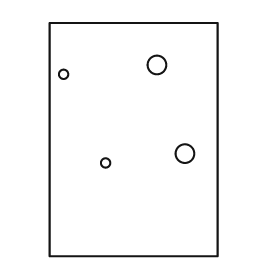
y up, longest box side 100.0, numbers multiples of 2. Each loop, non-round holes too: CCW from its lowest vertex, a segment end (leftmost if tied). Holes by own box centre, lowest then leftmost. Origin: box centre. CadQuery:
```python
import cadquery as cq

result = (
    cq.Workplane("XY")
    .moveTo(-36.0, -50.0)
    .lineTo(36.0, -50.0)
    .lineTo(36.0, 50.0)
    .lineTo(-36.0, 50.0)
    .close()
    .moveTo(-12.0, -10.0)
    .circle(2.0)
    .moveTo(22.0, -6.0)
    .circle(4.0)
    .moveTo(-30.0, 28.0)
    .circle(2.0)
    .moveTo(10.0, 32.0)
    .circle(4.0)
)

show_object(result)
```